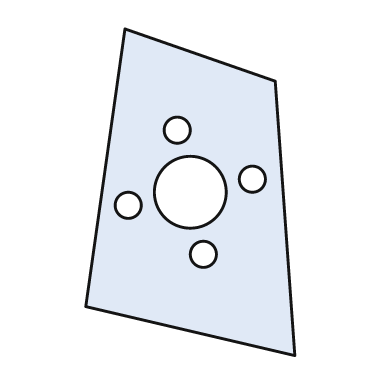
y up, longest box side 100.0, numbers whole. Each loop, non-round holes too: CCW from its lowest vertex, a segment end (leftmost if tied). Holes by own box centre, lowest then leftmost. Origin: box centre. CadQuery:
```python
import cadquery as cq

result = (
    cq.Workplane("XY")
    .moveTo(32.0, -50.0)
    .lineTo(26.0, 34.0)
    .lineTo(-20.0, 50.0)
    .lineTo(-32.0, -35.0)
    .close()
    .moveTo(4.0, -19.0)
    .circle(4.0)
    .moveTo(-19.0, -4.0)
    .circle(4.0)
    .moveTo(0.0, 0.0)
    .circle(11.0)
    .moveTo(19.0, 4.0)
    .circle(4.0)
    .moveTo(-4.0, 19.0)
    .circle(4.0)
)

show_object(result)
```